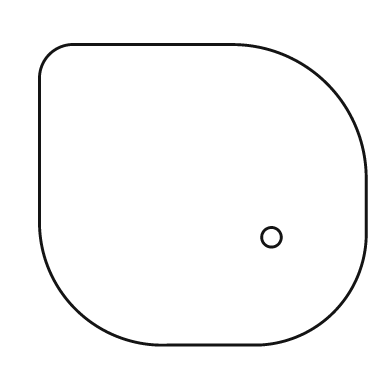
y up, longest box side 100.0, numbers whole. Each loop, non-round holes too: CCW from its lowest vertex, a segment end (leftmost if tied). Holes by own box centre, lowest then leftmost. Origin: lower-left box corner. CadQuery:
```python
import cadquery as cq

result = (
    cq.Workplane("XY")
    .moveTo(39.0, 0.0)
    .lineTo(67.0, 0.0)
    .threePointArc((90.0, 10.0), (100.0, 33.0))
    .lineTo(100.0, 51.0)
    .threePointArc((88.0, 80.0), (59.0, 92.0))
    .lineTo(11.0, 92.0)
    .threePointArc((3.0, 89.0), (0.0, 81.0))
    .lineTo(0.0, 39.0)
    .threePointArc((11.0, 11.0), (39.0, 0.0))
    .close()
    .moveTo(71.0, 33.0)
    .circle(3.0)
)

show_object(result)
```